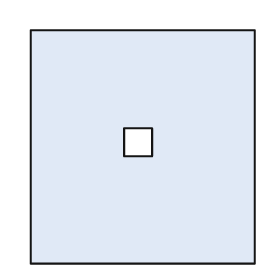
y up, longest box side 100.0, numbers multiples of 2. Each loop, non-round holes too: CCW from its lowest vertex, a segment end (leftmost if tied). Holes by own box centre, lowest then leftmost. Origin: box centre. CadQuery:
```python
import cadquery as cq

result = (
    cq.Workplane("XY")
    .moveTo(-48.0, -50.0)
    .lineTo(48.0, -50.0)
    .lineTo(48.0, 50.0)
    .lineTo(-48.0, 50.0)
    .close()
    .moveTo(-8.0, -4.0)
    .lineTo(4.0, -4.0)
    .lineTo(4.0, 8.0)
    .lineTo(-8.0, 8.0)
    .close()
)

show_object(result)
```